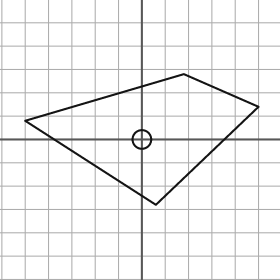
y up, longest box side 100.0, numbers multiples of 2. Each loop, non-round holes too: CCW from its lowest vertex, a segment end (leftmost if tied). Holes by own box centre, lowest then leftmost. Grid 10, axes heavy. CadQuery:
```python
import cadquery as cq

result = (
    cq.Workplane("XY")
    .moveTo(6.0, -28.0)
    .lineTo(50.0, 14.0)
    .lineTo(18.0, 28.0)
    .lineTo(-50.0, 8.0)
    .close()
    .moveTo(0.0, 0.0)
    .circle(4.0)
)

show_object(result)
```